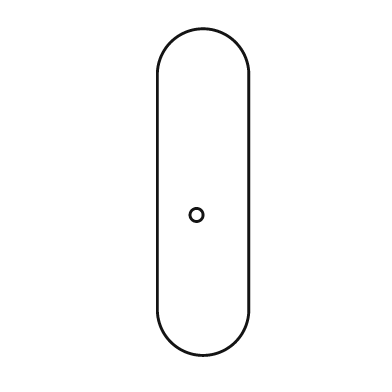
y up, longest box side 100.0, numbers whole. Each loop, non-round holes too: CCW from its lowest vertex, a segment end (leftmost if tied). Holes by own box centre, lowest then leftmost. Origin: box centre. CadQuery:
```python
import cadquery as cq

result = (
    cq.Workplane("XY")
    .moveTo(-14.0, -36.0)
    .threePointArc((0.0, -50.0), (14.0, -36.0))
    .lineTo(14.0, 36.0)
    .threePointArc((0.0, 50.0), (-14.0, 36.0))
    .close()
    .moveTo(-2.0, -7.0)
    .circle(2.0)
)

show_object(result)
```